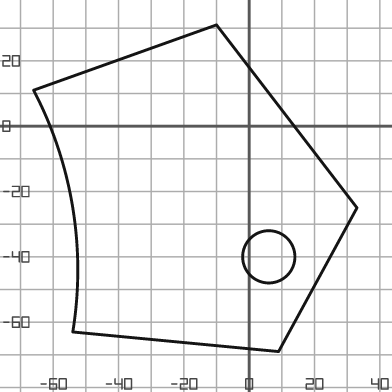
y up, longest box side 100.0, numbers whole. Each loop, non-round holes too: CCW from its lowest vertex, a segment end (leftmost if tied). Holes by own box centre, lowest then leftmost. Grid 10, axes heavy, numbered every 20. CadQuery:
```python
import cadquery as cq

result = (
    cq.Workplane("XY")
    .moveTo(9.0, -69.0)
    .lineTo(33.0, -25.0)
    .lineTo(-10.0, 31.0)
    .lineTo(-66.0, 11.0)
    .threePointArc((-54.0, -25.0), (-54.0, -63.0))
    .close()
    .moveTo(6.0, -40.0)
    .circle(8.0)
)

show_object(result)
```